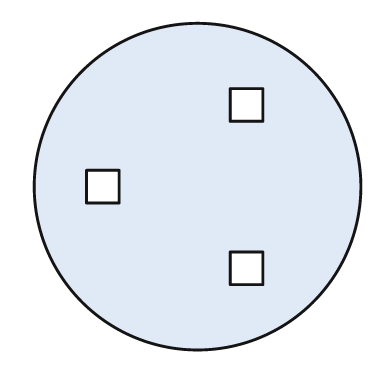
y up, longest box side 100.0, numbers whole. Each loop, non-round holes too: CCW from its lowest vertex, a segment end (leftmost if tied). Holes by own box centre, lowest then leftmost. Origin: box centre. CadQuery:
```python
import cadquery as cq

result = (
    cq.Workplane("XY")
    .moveTo(0.0, 0.0)
    .circle(50.0)
    .moveTo(10.0, -30.0)
    .lineTo(20.0, -30.0)
    .lineTo(20.0, -20.0)
    .lineTo(10.0, -20.0)
    .close()
    .moveTo(-34.0, -5.0)
    .lineTo(-24.0, -5.0)
    .lineTo(-24.0, 5.0)
    .lineTo(-34.0, 5.0)
    .close()
    .moveTo(10.0, 20.0)
    .lineTo(20.0, 20.0)
    .lineTo(20.0, 30.0)
    .lineTo(10.0, 30.0)
    .close()
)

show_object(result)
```